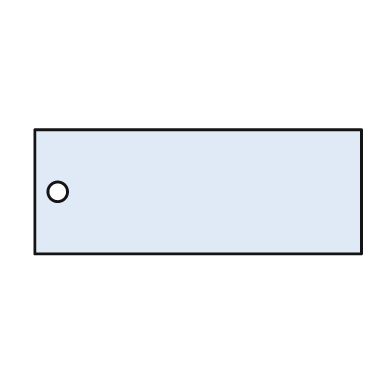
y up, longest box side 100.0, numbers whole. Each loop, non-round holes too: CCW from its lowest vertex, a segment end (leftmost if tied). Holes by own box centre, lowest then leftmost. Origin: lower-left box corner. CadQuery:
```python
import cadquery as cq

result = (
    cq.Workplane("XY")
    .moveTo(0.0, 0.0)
    .lineTo(100.0, 0.0)
    .lineTo(100.0, 38.0)
    .lineTo(0.0, 38.0)
    .close()
    .moveTo(7.0, 19.0)
    .circle(3.0)
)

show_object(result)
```